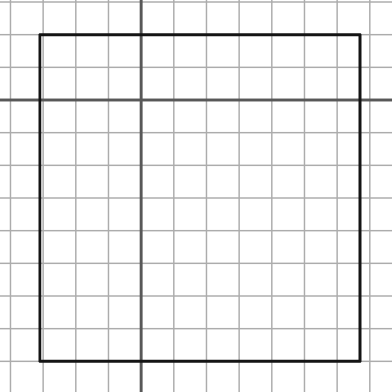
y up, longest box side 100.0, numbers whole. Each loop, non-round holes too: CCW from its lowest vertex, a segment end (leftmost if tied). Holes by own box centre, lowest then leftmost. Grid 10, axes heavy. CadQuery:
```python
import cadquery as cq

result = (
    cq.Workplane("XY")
    .moveTo(-31.0, -80.0)
    .lineTo(67.0, -80.0)
    .lineTo(67.0, 20.0)
    .lineTo(-31.0, 20.0)
    .close()
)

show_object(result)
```